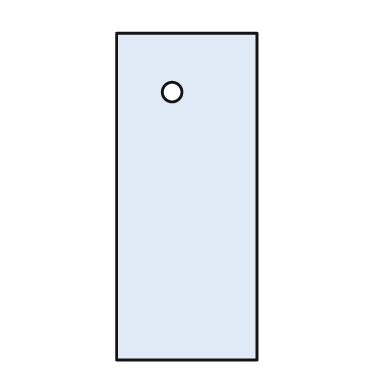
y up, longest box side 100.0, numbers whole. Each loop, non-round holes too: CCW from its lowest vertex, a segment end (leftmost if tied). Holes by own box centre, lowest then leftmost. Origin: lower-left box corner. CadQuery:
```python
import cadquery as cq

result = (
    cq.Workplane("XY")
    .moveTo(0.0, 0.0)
    .lineTo(43.0, 0.0)
    .lineTo(43.0, 100.0)
    .lineTo(0.0, 100.0)
    .close()
    .moveTo(17.0, 82.0)
    .circle(3.0)
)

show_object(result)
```